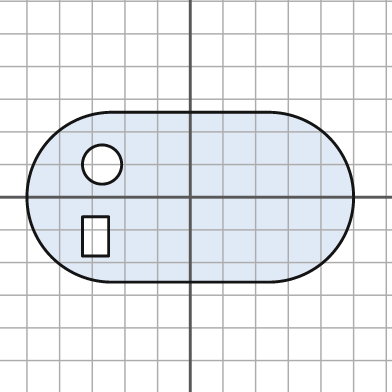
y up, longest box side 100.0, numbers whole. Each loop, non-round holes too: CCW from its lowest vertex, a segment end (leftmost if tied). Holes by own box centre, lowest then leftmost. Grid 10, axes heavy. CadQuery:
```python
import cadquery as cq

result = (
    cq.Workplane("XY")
    .moveTo(-24.0, -26.0)
    .lineTo(24.0, -26.0)
    .threePointArc((50.0, 0.0), (24.0, 26.0))
    .lineTo(-24.0, 26.0)
    .threePointArc((-50.0, 0.0), (-24.0, -26.0))
    .close()
    .moveTo(-33.0, -18.0)
    .lineTo(-25.0, -18.0)
    .lineTo(-25.0, -6.0)
    .lineTo(-33.0, -6.0)
    .close()
    .moveTo(-27.0, 10.0)
    .circle(6.0)
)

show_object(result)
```